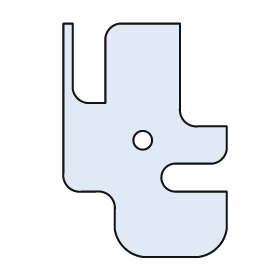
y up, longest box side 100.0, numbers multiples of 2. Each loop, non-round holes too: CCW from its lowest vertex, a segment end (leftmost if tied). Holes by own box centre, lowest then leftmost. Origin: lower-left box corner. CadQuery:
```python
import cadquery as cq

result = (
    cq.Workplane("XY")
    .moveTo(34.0, 0.0)
    .lineTo(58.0, 0.0)
    .threePointArc((66.0, 4.0), (70.0, 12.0))
    .lineTo(70.0, 28.0)
    .lineTo(48.0, 28.0)
    .threePointArc((42.0, 34.0), (48.0, 40.0))
    .lineTo(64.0, 40.0)
    .threePointArc((68.0, 42.0), (70.0, 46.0))
    .lineTo(70.0, 56.0)
    .lineTo(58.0, 56.0)
    .threePointArc((52.0, 58.0), (50.0, 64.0))
    .lineTo(50.0, 100.0)
    .lineTo(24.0, 100.0)
    .threePointArc((20.0, 98.0), (18.0, 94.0))
    .lineTo(18.0, 66.0)
    .lineTo(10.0, 66.0)
    .threePointArc((6.0, 68.0), (4.0, 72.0))
    .lineTo(4.0, 100.0)
    .lineTo(0.0, 100.0)
    .lineTo(0.0, 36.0)
    .threePointArc((2.0, 30.0), (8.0, 28.0))
    .lineTo(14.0, 28.0)
    .threePointArc((20.0, 26.0), (22.0, 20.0))
    .lineTo(22.0, 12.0)
    .threePointArc((26.0, 4.0), (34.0, 0.0))
    .close()
    .moveTo(34.0, 50.0)
    .circle(4.0)
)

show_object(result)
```